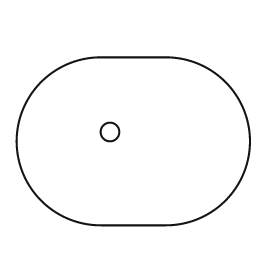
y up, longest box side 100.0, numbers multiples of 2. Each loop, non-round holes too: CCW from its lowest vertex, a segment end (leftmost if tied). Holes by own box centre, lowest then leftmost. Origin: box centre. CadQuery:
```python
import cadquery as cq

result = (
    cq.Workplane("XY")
    .moveTo(-14.0, -36.0)
    .lineTo(14.0, -36.0)
    .threePointArc((50.0, 0.0), (14.0, 36.0))
    .lineTo(-14.0, 36.0)
    .threePointArc((-50.0, 0.0), (-14.0, -36.0))
    .close()
    .moveTo(-10.0, 4.0)
    .circle(4.0)
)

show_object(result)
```